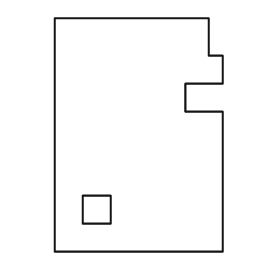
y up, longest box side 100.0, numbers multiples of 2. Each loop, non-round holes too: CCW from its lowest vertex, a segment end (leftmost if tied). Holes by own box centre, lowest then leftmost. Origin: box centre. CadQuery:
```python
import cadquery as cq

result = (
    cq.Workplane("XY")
    .moveTo(-36.0, -50.0)
    .lineTo(36.0, -50.0)
    .lineTo(36.0, 10.0)
    .lineTo(20.0, 10.0)
    .lineTo(20.0, 22.0)
    .lineTo(36.0, 22.0)
    .lineTo(36.0, 34.0)
    .lineTo(30.0, 34.0)
    .lineTo(30.0, 50.0)
    .lineTo(-36.0, 50.0)
    .close()
    .moveTo(-24.0, -38.0)
    .lineTo(-12.0, -38.0)
    .lineTo(-12.0, -26.0)
    .lineTo(-24.0, -26.0)
    .close()
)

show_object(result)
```